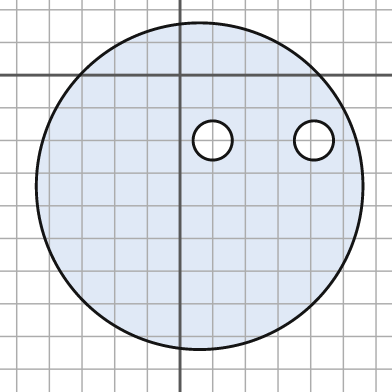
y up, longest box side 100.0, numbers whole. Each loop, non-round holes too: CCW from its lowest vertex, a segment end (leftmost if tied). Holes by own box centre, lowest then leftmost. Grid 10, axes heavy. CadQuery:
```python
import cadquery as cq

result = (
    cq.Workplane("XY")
    .moveTo(6.0, -34.0)
    .circle(50.0)
    .moveTo(10.0, -20.0)
    .circle(6.0)
    .moveTo(41.0, -20.0)
    .circle(6.0)
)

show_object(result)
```